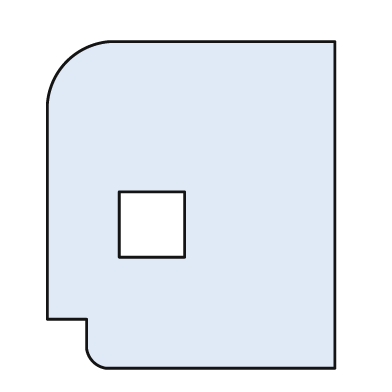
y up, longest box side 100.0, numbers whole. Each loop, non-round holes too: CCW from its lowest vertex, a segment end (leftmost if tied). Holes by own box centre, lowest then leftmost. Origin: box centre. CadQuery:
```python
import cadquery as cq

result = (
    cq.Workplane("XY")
    .moveTo(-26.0, -50.0)
    .lineTo(44.0, -50.0)
    .lineTo(44.0, 50.0)
    .lineTo(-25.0, 50.0)
    .threePointArc((-38.0, 44.0), (-44.0, 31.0))
    .lineTo(-44.0, -35.0)
    .lineTo(-32.0, -35.0)
    .lineTo(-32.0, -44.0)
    .threePointArc((-30.0, -48.0), (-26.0, -50.0))
    .close()
    .moveTo(-22.0, -16.0)
    .lineTo(-2.0, -16.0)
    .lineTo(-2.0, 4.0)
    .lineTo(-22.0, 4.0)
    .close()
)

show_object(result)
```